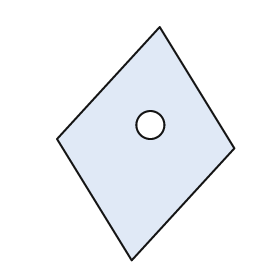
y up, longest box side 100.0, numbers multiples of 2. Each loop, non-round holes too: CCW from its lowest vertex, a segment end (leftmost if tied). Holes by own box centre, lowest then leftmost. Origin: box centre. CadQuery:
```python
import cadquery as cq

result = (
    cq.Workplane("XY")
    .moveTo(-6.0, -50.0)
    .lineTo(38.0, -2.0)
    .lineTo(6.0, 50.0)
    .lineTo(-38.0, 2.0)
    .close()
    .moveTo(2.0, 8.0)
    .circle(6.0)
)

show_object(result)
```